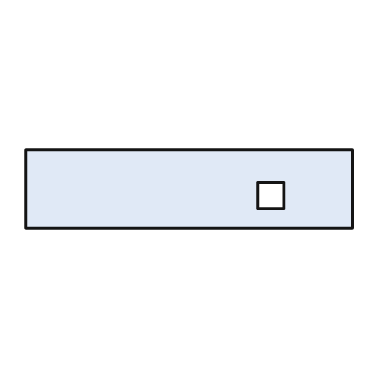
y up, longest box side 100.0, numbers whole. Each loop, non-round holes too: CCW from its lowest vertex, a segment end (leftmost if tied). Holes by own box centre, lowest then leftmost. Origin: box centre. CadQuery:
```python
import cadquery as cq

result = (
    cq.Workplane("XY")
    .moveTo(-50.0, -12.0)
    .lineTo(50.0, -12.0)
    .lineTo(50.0, 12.0)
    .lineTo(-50.0, 12.0)
    .close()
    .moveTo(21.0, -6.0)
    .lineTo(29.0, -6.0)
    .lineTo(29.0, 2.0)
    .lineTo(21.0, 2.0)
    .close()
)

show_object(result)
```